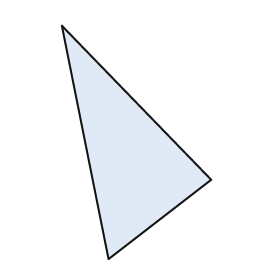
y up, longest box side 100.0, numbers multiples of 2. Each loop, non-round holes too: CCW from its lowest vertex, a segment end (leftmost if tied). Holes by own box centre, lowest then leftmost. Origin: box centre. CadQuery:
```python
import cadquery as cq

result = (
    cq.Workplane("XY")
    .moveTo(-12.0, -50.0)
    .lineTo(32.0, -16.0)
    .lineTo(-32.0, 50.0)
    .close()
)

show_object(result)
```